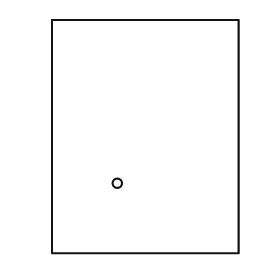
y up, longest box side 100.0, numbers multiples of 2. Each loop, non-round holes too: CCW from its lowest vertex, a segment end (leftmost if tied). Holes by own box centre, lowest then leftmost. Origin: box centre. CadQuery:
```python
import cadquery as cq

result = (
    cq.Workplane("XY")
    .moveTo(-40.0, -50.0)
    .lineTo(40.0, -50.0)
    .lineTo(40.0, 50.0)
    .lineTo(-40.0, 50.0)
    .close()
    .moveTo(-12.0, -20.0)
    .circle(2.0)
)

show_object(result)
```